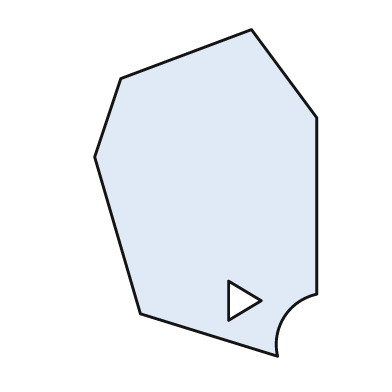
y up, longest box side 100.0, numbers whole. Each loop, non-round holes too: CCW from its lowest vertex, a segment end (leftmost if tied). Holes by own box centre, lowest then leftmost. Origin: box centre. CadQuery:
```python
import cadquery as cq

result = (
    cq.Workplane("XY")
    .moveTo(22.0, -50.0)
    .threePointArc((24.0, -38.0), (34.0, -31.0))
    .lineTo(34.0, 23.0)
    .lineTo(14.0, 50.0)
    .lineTo(-26.0, 35.0)
    .lineTo(-34.0, 11.0)
    .lineTo(-20.0, -37.0)
    .close()
    .moveTo(7.0, -39.0)
    .lineTo(17.0, -33.0)
    .lineTo(7.0, -27.0)
    .close()
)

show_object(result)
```